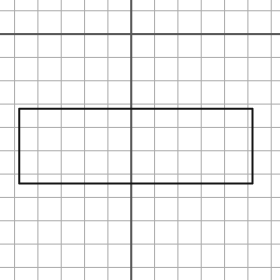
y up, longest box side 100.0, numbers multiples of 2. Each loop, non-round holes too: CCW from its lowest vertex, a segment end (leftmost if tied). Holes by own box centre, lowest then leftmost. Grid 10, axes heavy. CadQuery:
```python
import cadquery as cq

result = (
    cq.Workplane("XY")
    .moveTo(-48.0, -64.0)
    .lineTo(52.0, -64.0)
    .lineTo(52.0, -32.0)
    .lineTo(-48.0, -32.0)
    .close()
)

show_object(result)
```